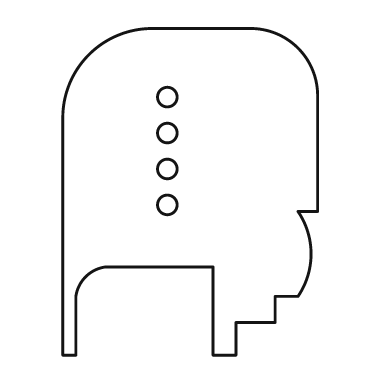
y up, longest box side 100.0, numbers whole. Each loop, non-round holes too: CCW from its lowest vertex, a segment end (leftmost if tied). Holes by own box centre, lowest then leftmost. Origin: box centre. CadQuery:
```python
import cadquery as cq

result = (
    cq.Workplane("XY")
    .moveTo(-39.0, -50.0)
    .lineTo(-35.0, -50.0)
    .lineTo(-35.0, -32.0)
    .threePointArc((-32.0, -26.0), (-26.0, -23.0))
    .lineTo(7.0, -23.0)
    .lineTo(7.0, -50.0)
    .lineTo(14.0, -50.0)
    .lineTo(14.0, -40.0)
    .lineTo(26.0, -40.0)
    .lineTo(26.0, -32.0)
    .lineTo(33.0, -32.0)
    .threePointArc((37.0, -19.0), (33.0, -6.0))
    .lineTo(39.0, -6.0)
    .lineTo(39.0, 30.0)
    .threePointArc((33.0, 44.0), (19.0, 50.0))
    .lineTo(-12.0, 50.0)
    .threePointArc((-31.0, 42.0), (-39.0, 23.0))
    .close()
    .moveTo(-7.0, -4.0)
    .circle(3.0)
    .moveTo(-7.0, 7.0)
    .circle(3.0)
    .moveTo(-7.0, 18.0)
    .circle(3.0)
    .moveTo(-7.0, 29.0)
    .circle(3.0)
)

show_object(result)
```